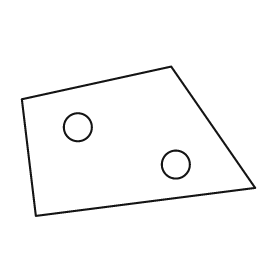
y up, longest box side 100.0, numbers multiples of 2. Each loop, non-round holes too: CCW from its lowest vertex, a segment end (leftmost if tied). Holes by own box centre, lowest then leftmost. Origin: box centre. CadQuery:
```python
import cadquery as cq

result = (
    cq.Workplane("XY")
    .moveTo(-44.0, -32.0)
    .lineTo(50.0, -20.0)
    .lineTo(14.0, 32.0)
    .lineTo(-50.0, 18.0)
    .close()
    .moveTo(16.0, -10.0)
    .circle(6.0)
    .moveTo(-26.0, 6.0)
    .circle(6.0)
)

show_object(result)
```